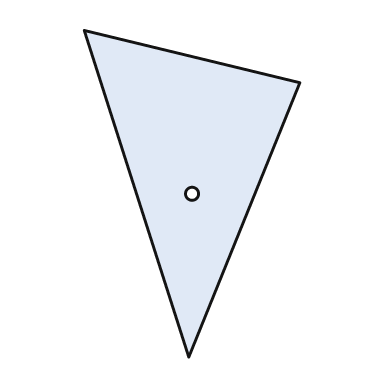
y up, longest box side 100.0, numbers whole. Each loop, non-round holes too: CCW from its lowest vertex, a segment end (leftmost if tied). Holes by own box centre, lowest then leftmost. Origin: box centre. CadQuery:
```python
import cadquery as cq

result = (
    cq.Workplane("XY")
    .moveTo(-1.0, -50.0)
    .lineTo(33.0, 34.0)
    .lineTo(-33.0, 50.0)
    .close()
    .moveTo(0.0, 0.0)
    .circle(2.0)
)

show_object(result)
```